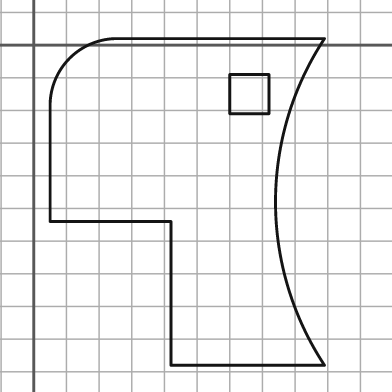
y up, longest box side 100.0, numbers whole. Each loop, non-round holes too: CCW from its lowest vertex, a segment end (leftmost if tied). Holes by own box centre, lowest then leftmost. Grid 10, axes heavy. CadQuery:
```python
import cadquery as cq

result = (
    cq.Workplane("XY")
    .moveTo(42.0, -98.0)
    .lineTo(89.0, -98.0)
    .threePointArc((74.0, -48.0), (89.0, 2.0))
    .lineTo(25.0, 2.0)
    .threePointArc((11.0, -4.0), (5.0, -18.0))
    .lineTo(5.0, -54.0)
    .lineTo(42.0, -54.0)
    .close()
    .moveTo(60.0, -21.0)
    .lineTo(72.0, -21.0)
    .lineTo(72.0, -9.0)
    .lineTo(60.0, -9.0)
    .close()
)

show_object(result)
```